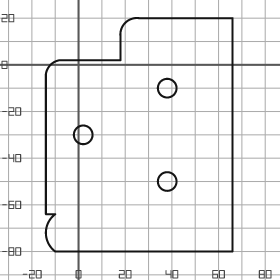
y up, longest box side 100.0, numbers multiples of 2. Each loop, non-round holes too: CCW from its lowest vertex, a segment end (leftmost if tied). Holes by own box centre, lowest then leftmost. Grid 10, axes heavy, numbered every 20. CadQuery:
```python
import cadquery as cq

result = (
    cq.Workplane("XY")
    .moveTo(-10.0, -80.0)
    .lineTo(66.0, -80.0)
    .lineTo(66.0, 20.0)
    .lineTo(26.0, 20.0)
    .threePointArc((20.0, 18.0), (18.0, 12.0))
    .lineTo(18.0, 2.0)
    .lineTo(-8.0, 2.0)
    .threePointArc((-12.0, 0.0), (-14.0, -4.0))
    .lineTo(-14.0, -64.0)
    .lineTo(-10.0, -64.0)
    .threePointArc((-14.0, -72.0), (-10.0, -80.0))
    .close()
    .moveTo(38.0, -50.0)
    .circle(4.0)
    .moveTo(2.0, -30.0)
    .circle(4.0)
    .moveTo(38.0, -10.0)
    .circle(4.0)
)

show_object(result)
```